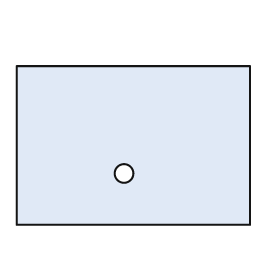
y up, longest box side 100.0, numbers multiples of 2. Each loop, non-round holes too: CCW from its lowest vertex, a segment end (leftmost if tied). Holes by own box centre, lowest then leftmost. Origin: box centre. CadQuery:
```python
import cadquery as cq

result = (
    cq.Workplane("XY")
    .moveTo(-50.0, -34.0)
    .lineTo(50.0, -34.0)
    .lineTo(50.0, 34.0)
    .lineTo(-50.0, 34.0)
    .close()
    .moveTo(-4.0, -12.0)
    .circle(4.0)
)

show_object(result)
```